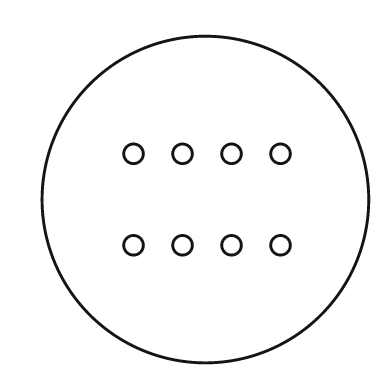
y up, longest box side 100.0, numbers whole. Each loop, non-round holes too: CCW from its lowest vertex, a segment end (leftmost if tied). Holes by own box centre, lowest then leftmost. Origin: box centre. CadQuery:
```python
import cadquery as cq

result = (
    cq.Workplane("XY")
    .moveTo(0.0, 0.0)
    .circle(50.0)
    .moveTo(-22.0, -14.0)
    .circle(3.0)
    .moveTo(-7.0, -14.0)
    .circle(3.0)
    .moveTo(8.0, -14.0)
    .circle(3.0)
    .moveTo(23.0, -14.0)
    .circle(3.0)
    .moveTo(-22.0, 14.0)
    .circle(3.0)
    .moveTo(-7.0, 14.0)
    .circle(3.0)
    .moveTo(8.0, 14.0)
    .circle(3.0)
    .moveTo(23.0, 14.0)
    .circle(3.0)
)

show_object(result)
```